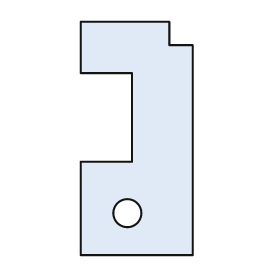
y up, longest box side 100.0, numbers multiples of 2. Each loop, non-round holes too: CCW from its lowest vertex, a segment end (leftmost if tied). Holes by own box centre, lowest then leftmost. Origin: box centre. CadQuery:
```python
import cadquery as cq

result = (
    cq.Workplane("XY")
    .moveTo(-24.0, -50.0)
    .lineTo(24.0, -50.0)
    .lineTo(24.0, 40.0)
    .lineTo(14.0, 40.0)
    .lineTo(14.0, 50.0)
    .lineTo(-24.0, 50.0)
    .lineTo(-24.0, 28.0)
    .lineTo(-2.0, 28.0)
    .lineTo(-2.0, -10.0)
    .lineTo(-24.0, -10.0)
    .close()
    .moveTo(-4.0, -32.0)
    .circle(6.0)
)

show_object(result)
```